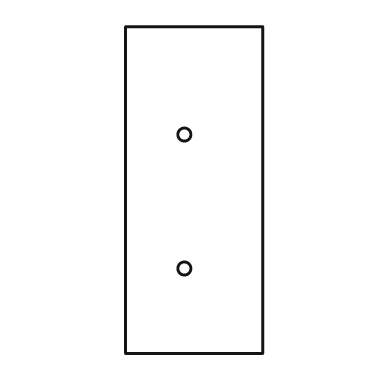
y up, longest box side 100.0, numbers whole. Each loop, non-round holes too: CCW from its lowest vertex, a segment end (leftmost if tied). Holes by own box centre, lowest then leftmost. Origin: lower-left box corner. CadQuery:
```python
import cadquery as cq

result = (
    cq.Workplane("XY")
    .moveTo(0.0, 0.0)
    .lineTo(42.0, 0.0)
    .lineTo(42.0, 100.0)
    .lineTo(0.0, 100.0)
    .close()
    .moveTo(18.0, 26.0)
    .circle(2.0)
    .moveTo(18.0, 67.0)
    .circle(2.0)
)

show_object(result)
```